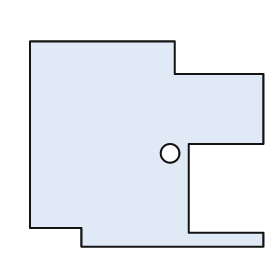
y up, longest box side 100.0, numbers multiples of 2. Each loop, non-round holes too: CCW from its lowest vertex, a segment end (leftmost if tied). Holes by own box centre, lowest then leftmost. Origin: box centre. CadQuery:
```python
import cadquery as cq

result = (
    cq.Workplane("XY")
    .moveTo(-28.0, -44.0)
    .lineTo(50.0, -44.0)
    .lineTo(50.0, -38.0)
    .lineTo(18.0, -38.0)
    .lineTo(18.0, 0.0)
    .lineTo(50.0, 0.0)
    .lineTo(50.0, 30.0)
    .lineTo(12.0, 30.0)
    .lineTo(12.0, 44.0)
    .lineTo(-50.0, 44.0)
    .lineTo(-50.0, -36.0)
    .lineTo(-28.0, -36.0)
    .close()
    .moveTo(10.0, -4.0)
    .circle(4.0)
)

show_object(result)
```